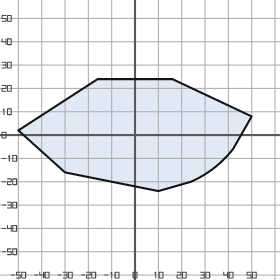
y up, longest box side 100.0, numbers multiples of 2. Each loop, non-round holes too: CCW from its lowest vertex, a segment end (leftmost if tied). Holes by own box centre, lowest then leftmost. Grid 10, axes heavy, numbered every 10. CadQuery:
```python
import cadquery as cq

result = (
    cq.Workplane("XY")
    .moveTo(10.0, -24.0)
    .lineTo(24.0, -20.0)
    .threePointArc((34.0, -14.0), (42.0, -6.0))
    .lineTo(50.0, 8.0)
    .lineTo(16.0, 24.0)
    .lineTo(-16.0, 24.0)
    .lineTo(-50.0, 2.0)
    .lineTo(-30.0, -16.0)
    .close()
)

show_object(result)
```